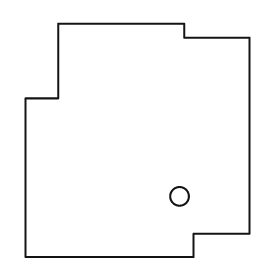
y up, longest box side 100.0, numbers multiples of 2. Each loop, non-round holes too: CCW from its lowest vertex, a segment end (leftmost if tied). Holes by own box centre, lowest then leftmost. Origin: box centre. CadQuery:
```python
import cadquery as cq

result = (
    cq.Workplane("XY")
    .moveTo(-48.0, -50.0)
    .lineTo(24.0, -50.0)
    .lineTo(24.0, -40.0)
    .lineTo(48.0, -40.0)
    .lineTo(48.0, 44.0)
    .lineTo(20.0, 44.0)
    .lineTo(20.0, 50.0)
    .lineTo(-34.0, 50.0)
    .lineTo(-34.0, 18.0)
    .lineTo(-48.0, 18.0)
    .close()
    .moveTo(18.0, -24.0)
    .circle(4.0)
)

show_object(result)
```